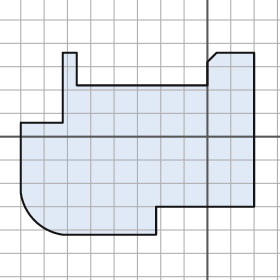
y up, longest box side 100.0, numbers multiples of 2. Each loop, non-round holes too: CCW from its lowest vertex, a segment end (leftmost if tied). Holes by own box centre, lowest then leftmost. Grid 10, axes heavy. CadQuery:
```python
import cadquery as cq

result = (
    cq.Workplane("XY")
    .moveTo(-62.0, -42.0)
    .lineTo(-22.0, -42.0)
    .lineTo(-22.0, -30.0)
    .lineTo(20.0, -30.0)
    .lineTo(20.0, 36.0)
    .lineTo(4.0, 36.0)
    .lineTo(0.0, 32.0)
    .lineTo(0.0, 22.0)
    .lineTo(-56.0, 22.0)
    .lineTo(-56.0, 36.0)
    .lineTo(-62.0, 36.0)
    .lineTo(-62.0, 6.0)
    .lineTo(-80.0, 6.0)
    .lineTo(-80.0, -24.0)
    .threePointArc((-74.0, -36.0), (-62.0, -42.0))
    .close()
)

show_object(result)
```